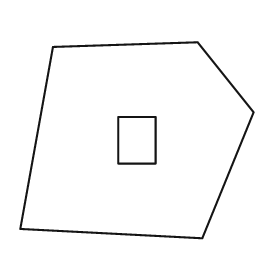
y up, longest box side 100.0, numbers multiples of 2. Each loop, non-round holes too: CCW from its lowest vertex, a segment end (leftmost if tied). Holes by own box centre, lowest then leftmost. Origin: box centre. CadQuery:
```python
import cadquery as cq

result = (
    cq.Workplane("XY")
    .moveTo(28.0, -42.0)
    .lineTo(50.0, 12.0)
    .lineTo(26.0, 42.0)
    .lineTo(-36.0, 40.0)
    .lineTo(-50.0, -38.0)
    .close()
    .moveTo(-8.0, -10.0)
    .lineTo(8.0, -10.0)
    .lineTo(8.0, 10.0)
    .lineTo(-8.0, 10.0)
    .close()
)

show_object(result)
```